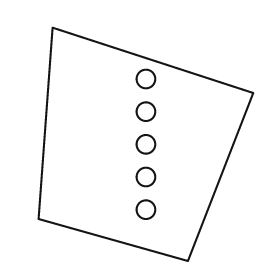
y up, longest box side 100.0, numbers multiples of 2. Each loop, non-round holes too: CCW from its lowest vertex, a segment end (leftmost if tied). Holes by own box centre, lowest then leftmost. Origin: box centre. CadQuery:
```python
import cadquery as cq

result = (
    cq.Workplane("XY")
    .moveTo(18.0, -50.0)
    .lineTo(46.0, 22.0)
    .lineTo(-40.0, 50.0)
    .lineTo(-46.0, -32.0)
    .close()
    .moveTo(0.0, -28.0)
    .circle(4.0)
    .moveTo(0.0, -14.0)
    .circle(4.0)
    .moveTo(0.0, 0.0)
    .circle(4.0)
    .moveTo(0.0, 14.0)
    .circle(4.0)
    .moveTo(0.0, 28.0)
    .circle(4.0)
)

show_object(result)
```